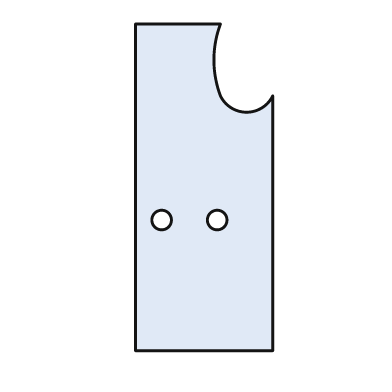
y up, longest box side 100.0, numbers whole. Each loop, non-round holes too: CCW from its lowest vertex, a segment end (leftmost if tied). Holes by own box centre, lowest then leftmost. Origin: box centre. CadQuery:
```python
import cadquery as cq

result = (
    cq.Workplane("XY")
    .moveTo(-21.0, -50.0)
    .lineTo(21.0, -50.0)
    .lineTo(21.0, 28.0)
    .threePointArc((13.0, 23.0), (5.0, 28.0))
    .threePointArc((3.0, 39.0), (5.0, 50.0))
    .lineTo(-21.0, 50.0)
    .close()
    .moveTo(-13.0, -10.0)
    .circle(3.0)
    .moveTo(4.0, -10.0)
    .circle(3.0)
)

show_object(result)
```